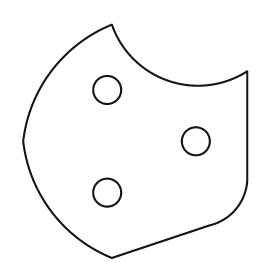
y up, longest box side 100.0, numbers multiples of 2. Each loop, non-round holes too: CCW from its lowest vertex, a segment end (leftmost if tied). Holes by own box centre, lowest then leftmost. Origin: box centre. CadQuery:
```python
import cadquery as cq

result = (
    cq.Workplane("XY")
    .moveTo(-10.0, -50.0)
    .lineTo(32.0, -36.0)
    .threePointArc((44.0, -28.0), (48.0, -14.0))
    .lineTo(48.0, 30.0)
    .threePointArc((14.0, 26.0), (-10.0, 50.0))
    .threePointArc((-36.0, 30.0), (-48.0, 0.0))
    .threePointArc((-36.0, -30.0), (-10.0, -50.0))
    .close()
    .moveTo(-12.0, -22.0)
    .circle(6.0)
    .moveTo(26.0, 0.0)
    .circle(6.0)
    .moveTo(-12.0, 22.0)
    .circle(6.0)
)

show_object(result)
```